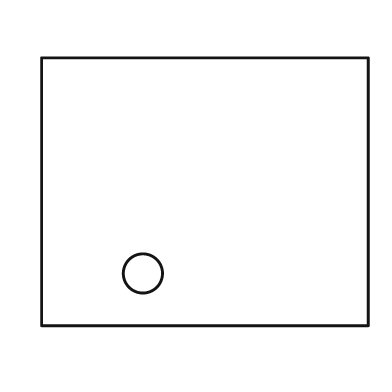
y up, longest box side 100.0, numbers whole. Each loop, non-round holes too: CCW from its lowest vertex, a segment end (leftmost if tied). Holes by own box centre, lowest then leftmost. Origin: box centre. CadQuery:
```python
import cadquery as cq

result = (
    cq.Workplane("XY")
    .moveTo(-50.0, -41.0)
    .lineTo(50.0, -41.0)
    .lineTo(50.0, 41.0)
    .lineTo(-50.0, 41.0)
    .close()
    .moveTo(-19.0, -25.0)
    .circle(6.0)
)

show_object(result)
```